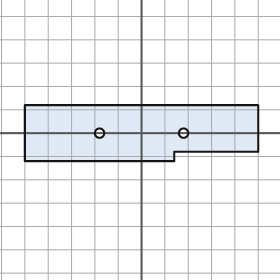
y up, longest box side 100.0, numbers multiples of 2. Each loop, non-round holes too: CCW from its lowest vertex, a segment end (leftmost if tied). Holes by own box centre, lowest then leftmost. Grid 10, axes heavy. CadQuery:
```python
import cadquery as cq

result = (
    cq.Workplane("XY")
    .moveTo(-50.0, -12.0)
    .lineTo(14.0, -12.0)
    .lineTo(14.0, -8.0)
    .lineTo(50.0, -8.0)
    .lineTo(50.0, 12.0)
    .lineTo(-50.0, 12.0)
    .close()
    .moveTo(-18.0, 0.0)
    .circle(2.0)
    .moveTo(18.0, 0.0)
    .circle(2.0)
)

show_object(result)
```